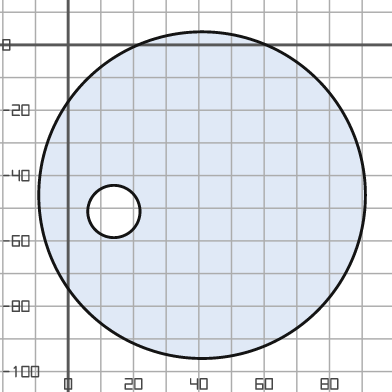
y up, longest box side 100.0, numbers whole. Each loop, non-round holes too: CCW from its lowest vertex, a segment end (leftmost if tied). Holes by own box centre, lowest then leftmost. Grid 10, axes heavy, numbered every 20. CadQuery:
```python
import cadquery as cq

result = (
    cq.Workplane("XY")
    .moveTo(41.0, -46.0)
    .circle(50.0)
    .moveTo(14.0, -51.0)
    .circle(8.0)
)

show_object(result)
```